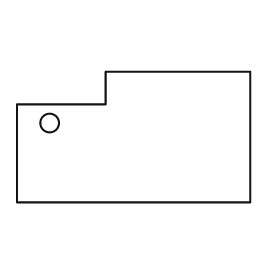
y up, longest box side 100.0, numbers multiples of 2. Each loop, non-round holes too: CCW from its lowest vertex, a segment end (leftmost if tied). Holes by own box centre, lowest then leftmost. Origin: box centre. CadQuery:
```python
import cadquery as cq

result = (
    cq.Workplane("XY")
    .moveTo(-50.0, -28.0)
    .lineTo(50.0, -28.0)
    .lineTo(50.0, 28.0)
    .lineTo(-12.0, 28.0)
    .lineTo(-12.0, 14.0)
    .lineTo(-50.0, 14.0)
    .close()
    .moveTo(-36.0, 6.0)
    .circle(4.0)
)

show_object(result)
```